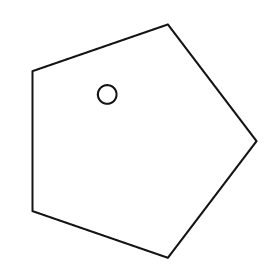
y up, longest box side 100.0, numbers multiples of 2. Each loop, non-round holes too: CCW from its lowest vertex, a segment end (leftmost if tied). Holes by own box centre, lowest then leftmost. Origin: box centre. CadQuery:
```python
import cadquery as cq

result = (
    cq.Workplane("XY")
    .moveTo(10.0, -50.0)
    .lineTo(48.0, 0.0)
    .lineTo(10.0, 50.0)
    .lineTo(-48.0, 30.0)
    .lineTo(-48.0, -30.0)
    .close()
    .moveTo(-16.0, 20.0)
    .circle(4.0)
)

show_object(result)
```